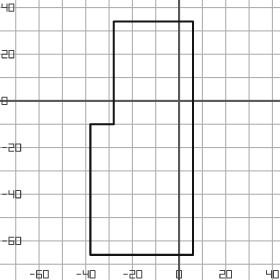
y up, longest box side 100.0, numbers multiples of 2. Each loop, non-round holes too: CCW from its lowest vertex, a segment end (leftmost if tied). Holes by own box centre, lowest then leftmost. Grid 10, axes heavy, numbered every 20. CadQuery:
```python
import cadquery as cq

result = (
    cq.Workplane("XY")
    .moveTo(-38.0, -66.0)
    .lineTo(6.0, -66.0)
    .lineTo(6.0, 34.0)
    .lineTo(-28.0, 34.0)
    .lineTo(-28.0, -10.0)
    .lineTo(-38.0, -10.0)
    .close()
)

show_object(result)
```